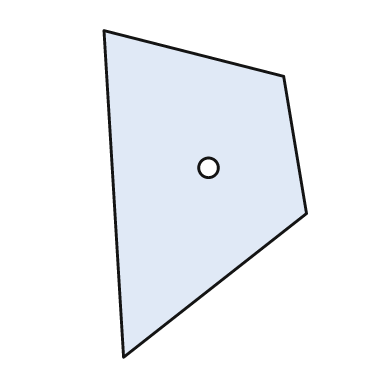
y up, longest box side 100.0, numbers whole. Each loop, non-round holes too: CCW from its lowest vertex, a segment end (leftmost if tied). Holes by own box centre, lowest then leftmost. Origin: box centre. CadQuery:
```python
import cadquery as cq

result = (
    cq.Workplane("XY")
    .moveTo(-25.0, -50.0)
    .lineTo(31.0, -6.0)
    .lineTo(24.0, 36.0)
    .lineTo(-31.0, 50.0)
    .close()
    .moveTo(1.0, 8.0)
    .circle(3.0)
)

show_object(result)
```